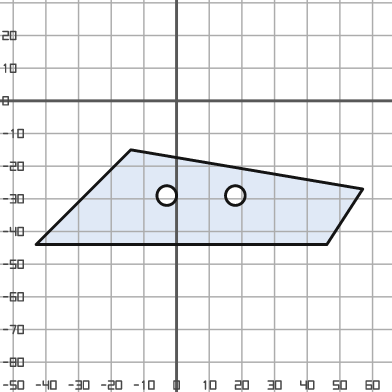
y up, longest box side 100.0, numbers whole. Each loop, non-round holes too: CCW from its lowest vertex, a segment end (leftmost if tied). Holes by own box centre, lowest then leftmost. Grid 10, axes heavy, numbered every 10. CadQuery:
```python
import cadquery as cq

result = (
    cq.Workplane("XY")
    .moveTo(-43.0, -44.0)
    .lineTo(46.0, -44.0)
    .lineTo(57.0, -27.0)
    .lineTo(-14.0, -15.0)
    .close()
    .moveTo(-3.0, -29.0)
    .circle(3.0)
    .moveTo(18.0, -29.0)
    .circle(3.0)
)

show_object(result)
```